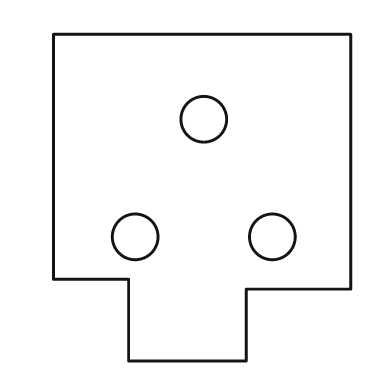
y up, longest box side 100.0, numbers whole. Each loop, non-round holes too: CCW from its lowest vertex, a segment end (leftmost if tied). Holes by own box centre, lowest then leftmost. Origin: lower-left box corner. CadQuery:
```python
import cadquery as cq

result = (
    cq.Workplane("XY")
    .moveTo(23.0, 0.0)
    .lineTo(59.0, 0.0)
    .lineTo(59.0, 22.0)
    .lineTo(91.0, 22.0)
    .lineTo(91.0, 100.0)
    .lineTo(0.0, 100.0)
    .lineTo(0.0, 25.0)
    .lineTo(23.0, 25.0)
    .close()
    .moveTo(25.0, 38.0)
    .circle(7.0)
    .moveTo(67.0, 38.0)
    .circle(7.0)
    .moveTo(46.0, 74.0)
    .circle(7.0)
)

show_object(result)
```